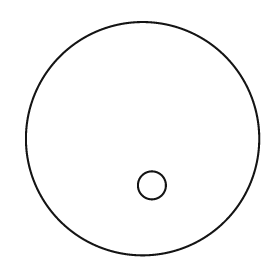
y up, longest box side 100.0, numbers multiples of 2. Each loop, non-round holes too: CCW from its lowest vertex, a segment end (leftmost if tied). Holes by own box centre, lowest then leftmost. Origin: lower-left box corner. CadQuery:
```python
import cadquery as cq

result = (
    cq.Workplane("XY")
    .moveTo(50.0, 50.0)
    .circle(50.0)
    .moveTo(54.0, 30.0)
    .circle(6.0)
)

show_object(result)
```